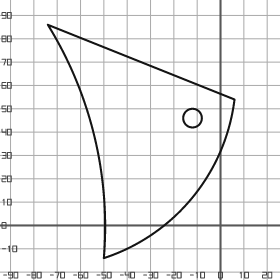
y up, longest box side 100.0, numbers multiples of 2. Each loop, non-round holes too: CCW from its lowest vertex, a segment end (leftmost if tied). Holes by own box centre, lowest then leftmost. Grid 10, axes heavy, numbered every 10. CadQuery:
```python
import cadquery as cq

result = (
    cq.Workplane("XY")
    .moveTo(-50.0, -14.0)
    .threePointArc((-12.0, 12.0), (6.0, 54.0))
    .lineTo(-74.0, 86.0)
    .threePointArc((-54.0, 38.0), (-50.0, -14.0))
    .close()
    .moveTo(-12.0, 46.0)
    .circle(4.0)
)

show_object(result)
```